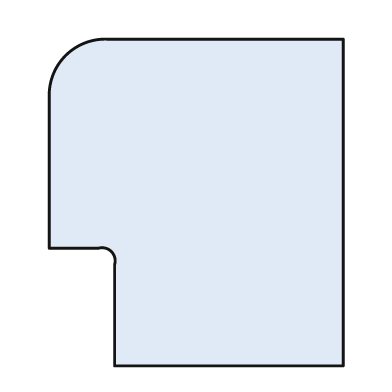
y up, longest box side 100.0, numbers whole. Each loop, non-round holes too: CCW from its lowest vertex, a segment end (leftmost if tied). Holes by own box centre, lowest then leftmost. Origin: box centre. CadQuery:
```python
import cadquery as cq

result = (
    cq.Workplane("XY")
    .moveTo(-25.0, -50.0)
    .lineTo(45.0, -50.0)
    .lineTo(45.0, 50.0)
    .lineTo(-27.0, 50.0)
    .threePointArc((-40.0, 45.0), (-45.0, 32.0))
    .lineTo(-45.0, -14.0)
    .lineTo(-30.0, -14.0)
    .threePointArc((-26.0, -15.0), (-25.0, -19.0))
    .close()
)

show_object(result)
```